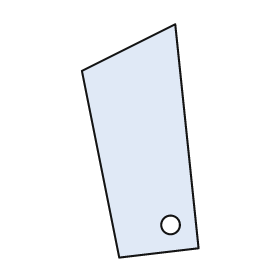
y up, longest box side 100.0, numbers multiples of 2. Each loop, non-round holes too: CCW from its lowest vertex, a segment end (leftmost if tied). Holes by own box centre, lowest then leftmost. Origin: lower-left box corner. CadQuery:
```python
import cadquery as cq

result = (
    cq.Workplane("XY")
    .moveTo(16.0, 0.0)
    .lineTo(50.0, 4.0)
    .lineTo(40.0, 100.0)
    .lineTo(0.0, 80.0)
    .close()
    .moveTo(38.0, 14.0)
    .circle(4.0)
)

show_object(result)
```